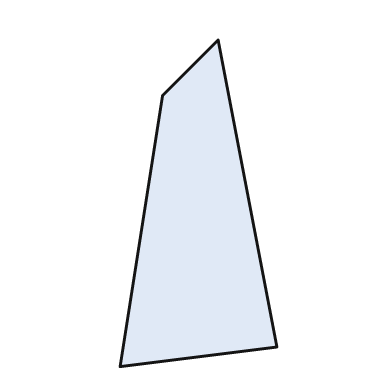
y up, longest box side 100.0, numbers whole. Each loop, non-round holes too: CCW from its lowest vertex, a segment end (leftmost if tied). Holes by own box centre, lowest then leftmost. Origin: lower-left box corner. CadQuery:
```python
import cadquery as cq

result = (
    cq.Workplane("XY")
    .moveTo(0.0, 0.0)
    .lineTo(48.0, 6.0)
    .lineTo(30.0, 100.0)
    .lineTo(13.0, 83.0)
    .close()
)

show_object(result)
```